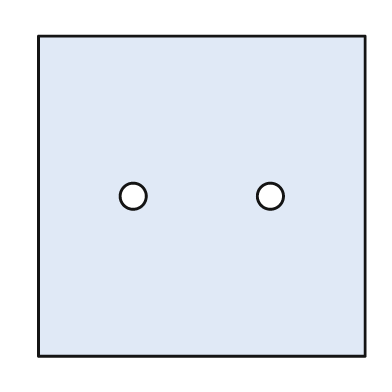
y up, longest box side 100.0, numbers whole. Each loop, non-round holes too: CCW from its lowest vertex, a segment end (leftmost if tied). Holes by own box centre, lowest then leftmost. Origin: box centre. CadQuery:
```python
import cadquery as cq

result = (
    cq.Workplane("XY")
    .moveTo(-50.0, -49.0)
    .lineTo(50.0, -49.0)
    .lineTo(50.0, 49.0)
    .lineTo(-50.0, 49.0)
    .close()
    .moveTo(-21.0, 0.0)
    .circle(4.0)
    .moveTo(21.0, 0.0)
    .circle(4.0)
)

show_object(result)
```